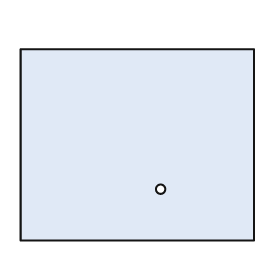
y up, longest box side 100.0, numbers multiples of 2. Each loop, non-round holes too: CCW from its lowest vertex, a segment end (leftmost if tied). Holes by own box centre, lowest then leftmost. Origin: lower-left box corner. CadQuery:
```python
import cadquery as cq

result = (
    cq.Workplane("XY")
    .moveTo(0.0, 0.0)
    .lineTo(100.0, 0.0)
    .lineTo(100.0, 82.0)
    .lineTo(0.0, 82.0)
    .close()
    .moveTo(60.0, 22.0)
    .circle(2.0)
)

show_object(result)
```